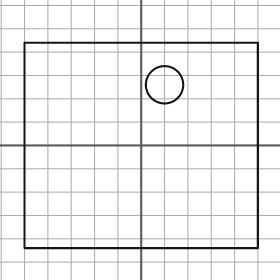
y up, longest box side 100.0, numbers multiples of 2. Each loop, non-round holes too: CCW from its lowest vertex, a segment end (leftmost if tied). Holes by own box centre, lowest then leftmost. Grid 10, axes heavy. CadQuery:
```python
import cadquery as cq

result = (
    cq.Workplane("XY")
    .moveTo(-50.0, -44.0)
    .lineTo(50.0, -44.0)
    .lineTo(50.0, 44.0)
    .lineTo(-50.0, 44.0)
    .close()
    .moveTo(10.0, 26.0)
    .circle(8.0)
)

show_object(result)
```